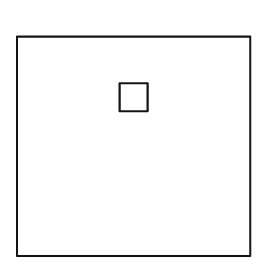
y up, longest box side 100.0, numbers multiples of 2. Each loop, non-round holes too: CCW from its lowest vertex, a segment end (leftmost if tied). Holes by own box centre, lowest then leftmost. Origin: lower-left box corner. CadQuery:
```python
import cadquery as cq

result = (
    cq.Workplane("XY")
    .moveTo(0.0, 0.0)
    .lineTo(100.0, 0.0)
    .lineTo(100.0, 94.0)
    .lineTo(0.0, 94.0)
    .close()
    .moveTo(44.0, 62.0)
    .lineTo(56.0, 62.0)
    .lineTo(56.0, 74.0)
    .lineTo(44.0, 74.0)
    .close()
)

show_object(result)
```